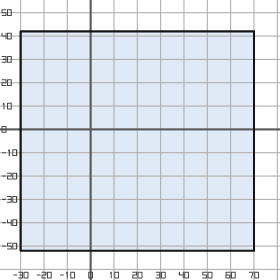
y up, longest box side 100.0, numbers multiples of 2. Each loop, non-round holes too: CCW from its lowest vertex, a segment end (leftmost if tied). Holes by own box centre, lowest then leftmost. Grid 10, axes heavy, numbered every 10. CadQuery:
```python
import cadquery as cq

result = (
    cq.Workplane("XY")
    .moveTo(-30.0, -52.0)
    .lineTo(70.0, -52.0)
    .lineTo(70.0, 42.0)
    .lineTo(-30.0, 42.0)
    .close()
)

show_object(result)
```